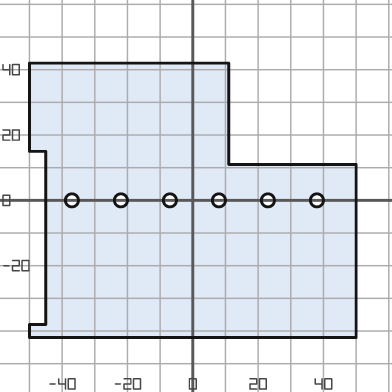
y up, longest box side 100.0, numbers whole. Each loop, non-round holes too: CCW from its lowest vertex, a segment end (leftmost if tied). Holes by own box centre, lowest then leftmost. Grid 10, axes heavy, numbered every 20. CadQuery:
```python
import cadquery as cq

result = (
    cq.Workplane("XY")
    .moveTo(-50.0, -42.0)
    .lineTo(50.0, -42.0)
    .lineTo(50.0, 11.0)
    .lineTo(11.0, 11.0)
    .lineTo(11.0, 42.0)
    .lineTo(-50.0, 42.0)
    .lineTo(-50.0, 15.0)
    .lineTo(-45.0, 15.0)
    .lineTo(-45.0, -38.0)
    .lineTo(-50.0, -38.0)
    .close()
    .moveTo(-37.0, 0.0)
    .circle(2.0)
    .moveTo(-22.0, 0.0)
    .circle(2.0)
    .moveTo(-7.0, 0.0)
    .circle(2.0)
    .moveTo(8.0, 0.0)
    .circle(2.0)
    .moveTo(23.0, 0.0)
    .circle(2.0)
    .moveTo(38.0, 0.0)
    .circle(2.0)
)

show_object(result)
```